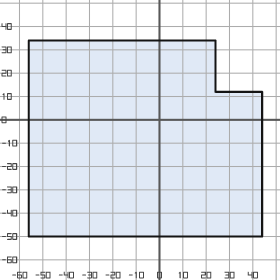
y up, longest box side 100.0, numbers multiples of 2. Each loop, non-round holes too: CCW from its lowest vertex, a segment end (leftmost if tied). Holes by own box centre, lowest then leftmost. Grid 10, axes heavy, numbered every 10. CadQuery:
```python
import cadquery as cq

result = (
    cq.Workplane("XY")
    .moveTo(-56.0, -50.0)
    .lineTo(44.0, -50.0)
    .lineTo(44.0, 12.0)
    .lineTo(24.0, 12.0)
    .lineTo(24.0, 34.0)
    .lineTo(-56.0, 34.0)
    .close()
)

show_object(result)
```